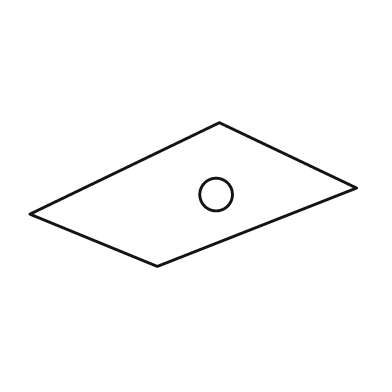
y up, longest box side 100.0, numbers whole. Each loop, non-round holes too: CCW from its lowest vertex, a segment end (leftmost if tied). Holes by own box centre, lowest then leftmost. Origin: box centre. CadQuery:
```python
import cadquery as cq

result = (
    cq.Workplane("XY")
    .moveTo(-11.0, -22.0)
    .lineTo(50.0, 2.0)
    .lineTo(8.0, 22.0)
    .lineTo(-50.0, -6.0)
    .close()
    .moveTo(7.0, 0.0)
    .circle(5.0)
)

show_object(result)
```